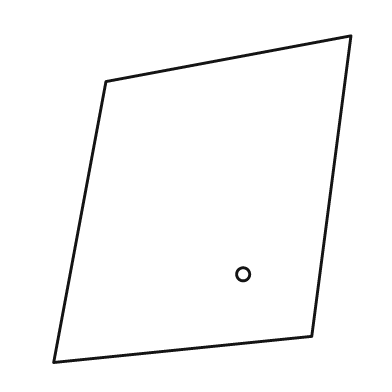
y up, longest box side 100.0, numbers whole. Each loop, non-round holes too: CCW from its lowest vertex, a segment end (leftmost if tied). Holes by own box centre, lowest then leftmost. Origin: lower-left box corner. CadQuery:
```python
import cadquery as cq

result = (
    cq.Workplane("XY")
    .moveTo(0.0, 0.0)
    .lineTo(79.0, 8.0)
    .lineTo(91.0, 100.0)
    .lineTo(16.0, 86.0)
    .close()
    .moveTo(58.0, 27.0)
    .circle(2.0)
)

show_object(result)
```